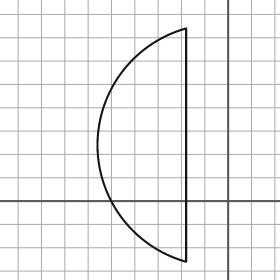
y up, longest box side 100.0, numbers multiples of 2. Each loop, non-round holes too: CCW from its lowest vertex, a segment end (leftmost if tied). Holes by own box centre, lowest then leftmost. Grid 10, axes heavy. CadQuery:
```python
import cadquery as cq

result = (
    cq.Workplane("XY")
    .moveTo(-18.0, -26.0)
    .lineTo(-18.0, 74.0)
    .threePointArc((-56.0, 24.0), (-18.0, -26.0))
    .close()
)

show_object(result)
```